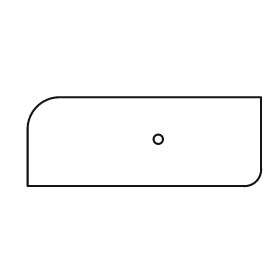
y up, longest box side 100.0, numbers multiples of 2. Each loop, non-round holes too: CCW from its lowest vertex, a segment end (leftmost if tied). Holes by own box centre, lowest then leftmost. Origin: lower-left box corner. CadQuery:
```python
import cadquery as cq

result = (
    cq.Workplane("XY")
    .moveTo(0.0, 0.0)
    .lineTo(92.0, 0.0)
    .threePointArc((98.0, 2.0), (100.0, 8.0))
    .lineTo(100.0, 38.0)
    .lineTo(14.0, 38.0)
    .threePointArc((4.0, 34.0), (0.0, 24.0))
    .close()
    .moveTo(56.0, 20.0)
    .circle(2.0)
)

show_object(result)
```